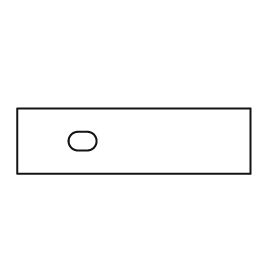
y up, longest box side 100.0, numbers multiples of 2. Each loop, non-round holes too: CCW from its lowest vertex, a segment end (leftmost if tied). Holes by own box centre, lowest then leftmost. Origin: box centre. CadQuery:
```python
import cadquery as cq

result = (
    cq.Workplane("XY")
    .moveTo(-50.0, -14.0)
    .lineTo(50.0, -14.0)
    .lineTo(50.0, 14.0)
    .lineTo(-50.0, 14.0)
    .close()
    .moveTo(-24.0, -4.0)
    .lineTo(-20.0, -4.0)
    .threePointArc((-16.0, 0.0), (-20.0, 4.0))
    .lineTo(-24.0, 4.0)
    .threePointArc((-28.0, 0.0), (-24.0, -4.0))
    .close()
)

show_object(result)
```